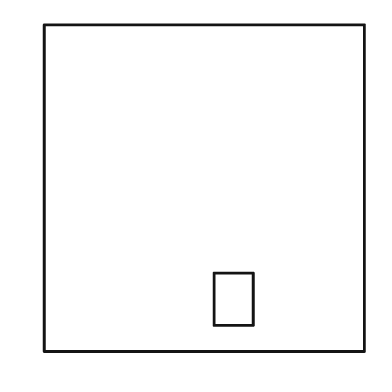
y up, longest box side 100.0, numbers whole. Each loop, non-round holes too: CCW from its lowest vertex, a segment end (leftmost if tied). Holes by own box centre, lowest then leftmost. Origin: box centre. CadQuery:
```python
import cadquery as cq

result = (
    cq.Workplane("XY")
    .moveTo(-49.0, -50.0)
    .lineTo(49.0, -50.0)
    .lineTo(49.0, 50.0)
    .lineTo(-49.0, 50.0)
    .close()
    .moveTo(3.0, -42.0)
    .lineTo(15.0, -42.0)
    .lineTo(15.0, -26.0)
    .lineTo(3.0, -26.0)
    .close()
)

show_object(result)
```